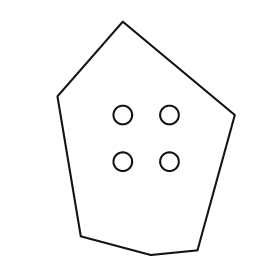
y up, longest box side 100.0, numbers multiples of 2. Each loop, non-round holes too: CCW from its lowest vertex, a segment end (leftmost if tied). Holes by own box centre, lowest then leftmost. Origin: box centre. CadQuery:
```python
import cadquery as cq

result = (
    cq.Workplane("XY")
    .moveTo(2.0, -50.0)
    .lineTo(22.0, -48.0)
    .lineTo(38.0, 10.0)
    .lineTo(-10.0, 50.0)
    .lineTo(-38.0, 18.0)
    .lineTo(-28.0, -42.0)
    .close()
    .moveTo(-10.0, -10.0)
    .circle(4.0)
    .moveTo(10.0, -10.0)
    .circle(4.0)
    .moveTo(-10.0, 10.0)
    .circle(4.0)
    .moveTo(10.0, 10.0)
    .circle(4.0)
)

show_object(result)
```